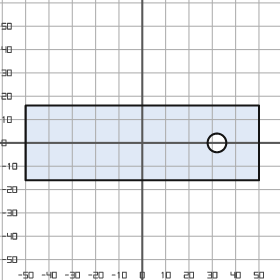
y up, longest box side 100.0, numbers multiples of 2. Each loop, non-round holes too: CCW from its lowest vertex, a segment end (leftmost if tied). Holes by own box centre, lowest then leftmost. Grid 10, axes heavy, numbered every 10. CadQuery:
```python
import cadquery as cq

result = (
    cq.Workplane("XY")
    .moveTo(-50.0, -16.0)
    .lineTo(50.0, -16.0)
    .lineTo(50.0, 16.0)
    .lineTo(-50.0, 16.0)
    .close()
    .moveTo(32.0, 0.0)
    .circle(4.0)
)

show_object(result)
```